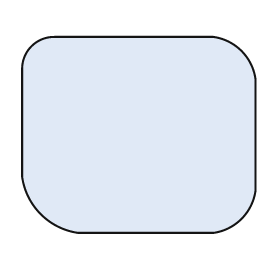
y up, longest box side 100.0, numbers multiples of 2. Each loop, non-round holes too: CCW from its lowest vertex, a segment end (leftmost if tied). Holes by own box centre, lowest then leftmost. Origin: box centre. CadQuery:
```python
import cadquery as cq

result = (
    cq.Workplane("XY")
    .moveTo(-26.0, -42.0)
    .lineTo(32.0, -42.0)
    .threePointArc((44.0, -36.0), (50.0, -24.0))
    .lineTo(50.0, 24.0)
    .threePointArc((44.0, 36.0), (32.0, 42.0))
    .lineTo(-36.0, 42.0)
    .threePointArc((-46.0, 38.0), (-50.0, 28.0))
    .lineTo(-50.0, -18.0)
    .threePointArc((-42.0, -34.0), (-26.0, -42.0))
    .close()
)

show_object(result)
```